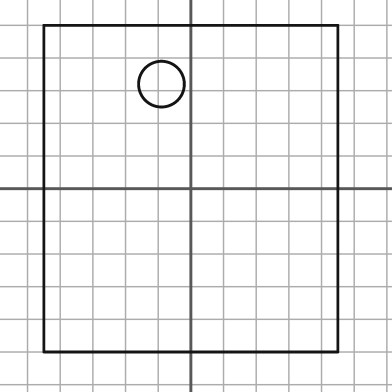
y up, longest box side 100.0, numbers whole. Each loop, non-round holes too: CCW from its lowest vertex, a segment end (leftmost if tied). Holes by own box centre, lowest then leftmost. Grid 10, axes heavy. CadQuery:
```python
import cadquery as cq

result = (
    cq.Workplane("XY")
    .moveTo(-45.0, -50.0)
    .lineTo(45.0, -50.0)
    .lineTo(45.0, 50.0)
    .lineTo(-45.0, 50.0)
    .close()
    .moveTo(-9.0, 32.0)
    .circle(7.0)
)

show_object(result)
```